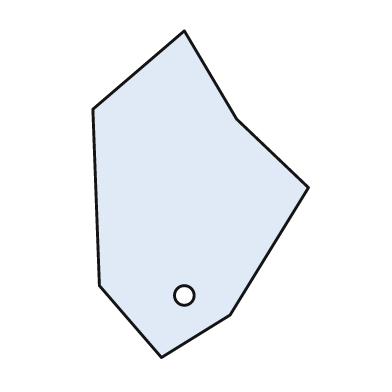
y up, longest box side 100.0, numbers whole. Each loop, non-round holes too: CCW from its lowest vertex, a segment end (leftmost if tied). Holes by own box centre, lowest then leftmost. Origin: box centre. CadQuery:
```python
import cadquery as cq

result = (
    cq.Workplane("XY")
    .moveTo(-12.0, -50.0)
    .lineTo(9.0, -37.0)
    .lineTo(33.0, 2.0)
    .lineTo(11.0, 23.0)
    .lineTo(-5.0, 50.0)
    .lineTo(-33.0, 26.0)
    .lineTo(-31.0, -28.0)
    .close()
    .moveTo(-5.0, -31.0)
    .circle(3.0)
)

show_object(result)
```